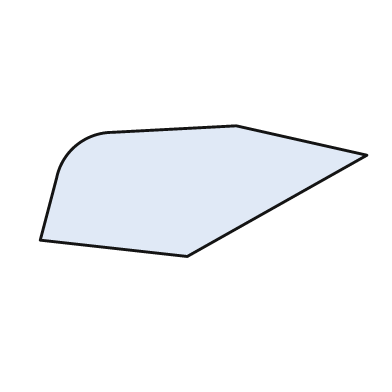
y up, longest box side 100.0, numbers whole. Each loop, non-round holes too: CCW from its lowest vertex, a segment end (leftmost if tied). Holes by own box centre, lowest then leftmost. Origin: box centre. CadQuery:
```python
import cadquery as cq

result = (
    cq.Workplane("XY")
    .moveTo(-5.0, -20.0)
    .lineTo(50.0, 11.0)
    .lineTo(10.0, 20.0)
    .lineTo(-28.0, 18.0)
    .threePointArc((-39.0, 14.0), (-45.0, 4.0))
    .lineTo(-50.0, -15.0)
    .close()
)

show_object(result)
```